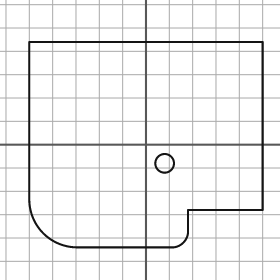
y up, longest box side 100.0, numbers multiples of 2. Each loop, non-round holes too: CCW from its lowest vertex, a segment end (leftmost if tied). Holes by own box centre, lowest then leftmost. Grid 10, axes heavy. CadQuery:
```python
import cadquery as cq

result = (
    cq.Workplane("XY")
    .moveTo(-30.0, -44.0)
    .lineTo(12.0, -44.0)
    .threePointArc((16.0, -42.0), (18.0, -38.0))
    .lineTo(18.0, -28.0)
    .lineTo(50.0, -28.0)
    .lineTo(50.0, 44.0)
    .lineTo(-50.0, 44.0)
    .lineTo(-50.0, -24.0)
    .threePointArc((-44.0, -38.0), (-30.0, -44.0))
    .close()
    .moveTo(8.0, -8.0)
    .circle(4.0)
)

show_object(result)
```